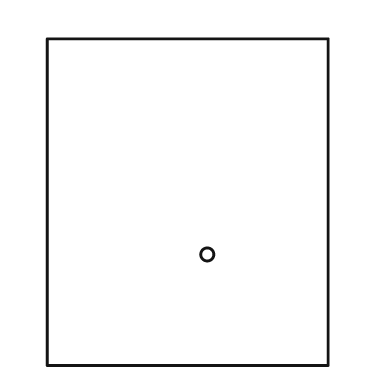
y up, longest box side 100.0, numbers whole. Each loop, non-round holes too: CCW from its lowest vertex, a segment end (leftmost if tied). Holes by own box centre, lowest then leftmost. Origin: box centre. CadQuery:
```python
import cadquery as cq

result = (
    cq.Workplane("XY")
    .moveTo(-43.0, -50.0)
    .lineTo(43.0, -50.0)
    .lineTo(43.0, 50.0)
    .lineTo(-43.0, 50.0)
    .close()
    .moveTo(6.0, -16.0)
    .circle(2.0)
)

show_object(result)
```